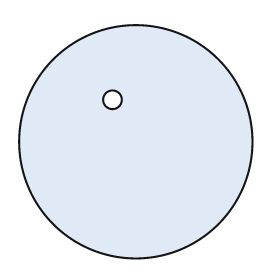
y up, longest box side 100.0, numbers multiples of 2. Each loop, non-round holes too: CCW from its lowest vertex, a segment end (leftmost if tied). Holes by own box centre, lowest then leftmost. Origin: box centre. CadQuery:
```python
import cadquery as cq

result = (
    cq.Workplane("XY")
    .moveTo(0.0, 0.0)
    .circle(50.0)
    .moveTo(-10.0, 18.0)
    .circle(4.0)
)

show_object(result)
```